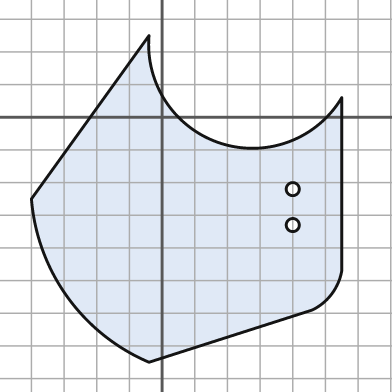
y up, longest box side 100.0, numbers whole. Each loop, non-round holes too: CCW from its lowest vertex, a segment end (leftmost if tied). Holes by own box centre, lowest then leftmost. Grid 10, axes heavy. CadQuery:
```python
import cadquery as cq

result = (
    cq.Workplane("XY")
    .moveTo(-4.0, -75.0)
    .lineTo(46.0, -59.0)
    .threePointArc((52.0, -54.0), (55.0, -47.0))
    .lineTo(55.0, 6.0)
    .threePointArc((18.0, -8.0), (-4.0, 25.0))
    .lineTo(-40.0, -25.0)
    .threePointArc((-29.0, -55.0), (-4.0, -75.0))
    .close()
    .moveTo(40.0, -33.0)
    .circle(2.0)
    .moveTo(40.0, -22.0)
    .circle(2.0)
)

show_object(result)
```